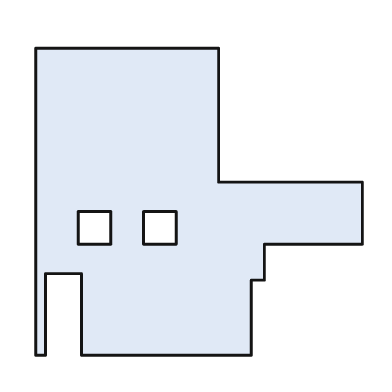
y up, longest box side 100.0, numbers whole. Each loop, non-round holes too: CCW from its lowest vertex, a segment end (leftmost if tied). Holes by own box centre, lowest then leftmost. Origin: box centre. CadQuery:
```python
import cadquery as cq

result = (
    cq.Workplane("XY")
    .moveTo(-50.0, -47.0)
    .lineTo(-47.0, -47.0)
    .lineTo(-47.0, -22.0)
    .lineTo(-36.0, -22.0)
    .lineTo(-36.0, -47.0)
    .lineTo(16.0, -47.0)
    .lineTo(16.0, -24.0)
    .lineTo(20.0, -24.0)
    .lineTo(20.0, -13.0)
    .lineTo(50.0, -13.0)
    .lineTo(50.0, 6.0)
    .lineTo(6.0, 6.0)
    .lineTo(6.0, 47.0)
    .lineTo(-50.0, 47.0)
    .close()
    .moveTo(-37.0, -13.0)
    .lineTo(-27.0, -13.0)
    .lineTo(-27.0, -3.0)
    .lineTo(-37.0, -3.0)
    .close()
    .moveTo(-17.0, -13.0)
    .lineTo(-7.0, -13.0)
    .lineTo(-7.0, -3.0)
    .lineTo(-17.0, -3.0)
    .close()
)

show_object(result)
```